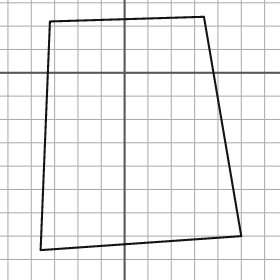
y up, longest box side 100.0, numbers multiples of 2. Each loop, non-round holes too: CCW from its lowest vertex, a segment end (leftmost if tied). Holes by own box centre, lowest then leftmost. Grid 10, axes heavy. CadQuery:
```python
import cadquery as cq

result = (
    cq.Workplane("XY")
    .moveTo(-36.0, -76.0)
    .lineTo(50.0, -70.0)
    .lineTo(34.0, 24.0)
    .lineTo(-32.0, 22.0)
    .close()
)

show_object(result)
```